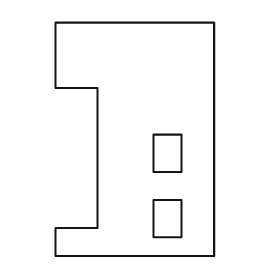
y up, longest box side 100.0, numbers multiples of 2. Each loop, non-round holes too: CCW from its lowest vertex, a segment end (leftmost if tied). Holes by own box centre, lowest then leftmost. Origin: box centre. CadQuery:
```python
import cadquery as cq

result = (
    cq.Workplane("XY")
    .moveTo(-34.0, -50.0)
    .lineTo(34.0, -50.0)
    .lineTo(34.0, 50.0)
    .lineTo(-34.0, 50.0)
    .lineTo(-34.0, 22.0)
    .lineTo(-16.0, 22.0)
    .lineTo(-16.0, -38.0)
    .lineTo(-34.0, -38.0)
    .close()
    .moveTo(8.0, -42.0)
    .lineTo(20.0, -42.0)
    .lineTo(20.0, -26.0)
    .lineTo(8.0, -26.0)
    .close()
    .moveTo(8.0, -14.0)
    .lineTo(20.0, -14.0)
    .lineTo(20.0, 2.0)
    .lineTo(8.0, 2.0)
    .close()
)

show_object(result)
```